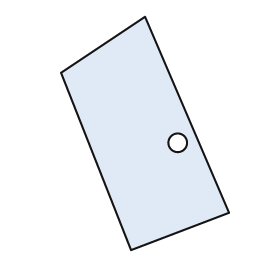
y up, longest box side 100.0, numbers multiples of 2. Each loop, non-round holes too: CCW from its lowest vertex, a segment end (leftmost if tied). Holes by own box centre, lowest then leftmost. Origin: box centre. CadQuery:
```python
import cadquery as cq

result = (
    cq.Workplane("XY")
    .moveTo(-6.0, -50.0)
    .lineTo(36.0, -34.0)
    .lineTo(0.0, 50.0)
    .lineTo(-36.0, 26.0)
    .close()
    .moveTo(14.0, -4.0)
    .circle(4.0)
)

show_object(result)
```